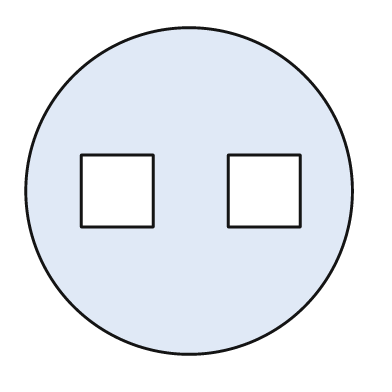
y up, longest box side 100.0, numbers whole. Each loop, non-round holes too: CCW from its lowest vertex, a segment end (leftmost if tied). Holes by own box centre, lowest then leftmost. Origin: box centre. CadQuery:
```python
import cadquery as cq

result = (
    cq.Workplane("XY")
    .moveTo(0.0, 0.0)
    .circle(50.0)
    .moveTo(-33.0, -11.0)
    .lineTo(-11.0, -11.0)
    .lineTo(-11.0, 11.0)
    .lineTo(-33.0, 11.0)
    .close()
    .moveTo(12.0, -11.0)
    .lineTo(34.0, -11.0)
    .lineTo(34.0, 11.0)
    .lineTo(12.0, 11.0)
    .close()
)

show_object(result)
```